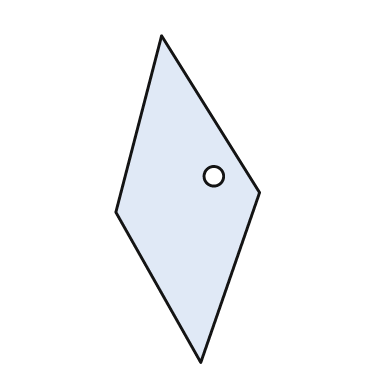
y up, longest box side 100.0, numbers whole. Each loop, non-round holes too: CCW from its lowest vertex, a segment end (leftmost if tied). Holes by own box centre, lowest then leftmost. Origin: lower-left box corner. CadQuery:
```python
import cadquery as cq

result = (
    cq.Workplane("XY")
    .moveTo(26.0, 0.0)
    .lineTo(44.0, 52.0)
    .lineTo(14.0, 100.0)
    .lineTo(0.0, 46.0)
    .close()
    .moveTo(30.0, 57.0)
    .circle(3.0)
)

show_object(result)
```